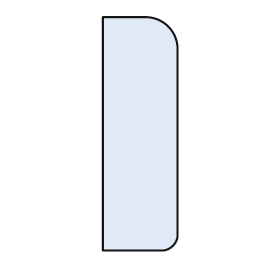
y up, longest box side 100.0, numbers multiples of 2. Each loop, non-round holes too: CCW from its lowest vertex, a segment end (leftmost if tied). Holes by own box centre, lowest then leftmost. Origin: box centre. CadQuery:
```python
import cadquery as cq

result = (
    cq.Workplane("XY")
    .moveTo(-16.0, -50.0)
    .lineTo(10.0, -50.0)
    .threePointArc((14.0, -48.0), (16.0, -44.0))
    .lineTo(16.0, 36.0)
    .threePointArc((12.0, 46.0), (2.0, 50.0))
    .lineTo(-16.0, 50.0)
    .close()
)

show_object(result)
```